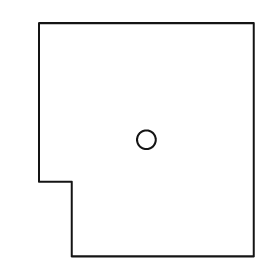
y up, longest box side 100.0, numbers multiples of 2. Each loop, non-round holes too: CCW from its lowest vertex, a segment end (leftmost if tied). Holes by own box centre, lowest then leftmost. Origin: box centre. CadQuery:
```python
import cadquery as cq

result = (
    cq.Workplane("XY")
    .moveTo(-32.0, -50.0)
    .lineTo(46.0, -50.0)
    .lineTo(46.0, 50.0)
    .lineTo(-46.0, 50.0)
    .lineTo(-46.0, -18.0)
    .lineTo(-32.0, -18.0)
    .close()
    .moveTo(0.0, 0.0)
    .circle(4.0)
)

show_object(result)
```